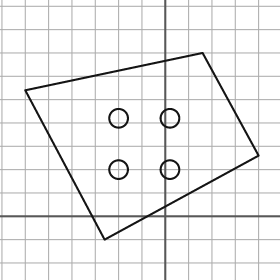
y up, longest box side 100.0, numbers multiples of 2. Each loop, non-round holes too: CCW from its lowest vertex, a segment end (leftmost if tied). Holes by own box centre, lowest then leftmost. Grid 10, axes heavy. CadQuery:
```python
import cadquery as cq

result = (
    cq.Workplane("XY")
    .moveTo(-26.0, -10.0)
    .lineTo(40.0, 26.0)
    .lineTo(16.0, 70.0)
    .lineTo(-60.0, 54.0)
    .close()
    .moveTo(-20.0, 20.0)
    .circle(4.0)
    .moveTo(2.0, 20.0)
    .circle(4.0)
    .moveTo(-20.0, 42.0)
    .circle(4.0)
    .moveTo(2.0, 42.0)
    .circle(4.0)
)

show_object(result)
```